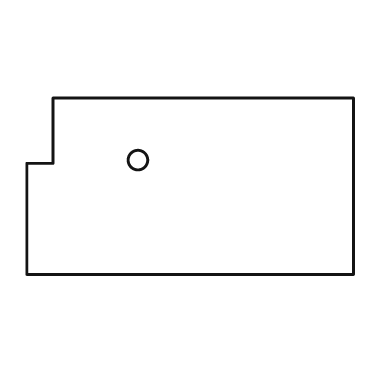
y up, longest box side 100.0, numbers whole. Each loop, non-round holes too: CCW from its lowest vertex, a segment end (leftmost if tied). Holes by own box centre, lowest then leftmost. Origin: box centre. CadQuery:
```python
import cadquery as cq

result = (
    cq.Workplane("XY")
    .moveTo(-50.0, -27.0)
    .lineTo(50.0, -27.0)
    .lineTo(50.0, 27.0)
    .lineTo(-42.0, 27.0)
    .lineTo(-42.0, 7.0)
    .lineTo(-50.0, 7.0)
    .close()
    .moveTo(-16.0, 8.0)
    .circle(3.0)
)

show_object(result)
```